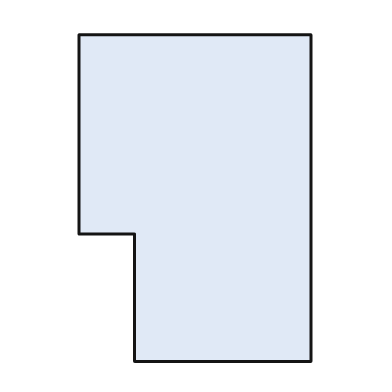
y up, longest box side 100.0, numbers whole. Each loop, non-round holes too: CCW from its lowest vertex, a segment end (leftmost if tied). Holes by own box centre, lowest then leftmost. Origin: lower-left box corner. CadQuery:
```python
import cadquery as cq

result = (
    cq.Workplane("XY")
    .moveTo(17.0, 0.0)
    .lineTo(71.0, 0.0)
    .lineTo(71.0, 100.0)
    .lineTo(0.0, 100.0)
    .lineTo(0.0, 39.0)
    .lineTo(17.0, 39.0)
    .close()
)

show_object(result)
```